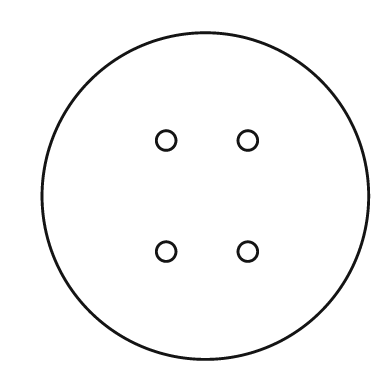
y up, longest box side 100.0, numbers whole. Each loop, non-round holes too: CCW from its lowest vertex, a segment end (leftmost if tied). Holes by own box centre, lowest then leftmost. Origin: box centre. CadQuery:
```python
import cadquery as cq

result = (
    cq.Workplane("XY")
    .moveTo(0.0, 0.0)
    .circle(50.0)
    .moveTo(-12.0, -17.0)
    .circle(3.0)
    .moveTo(13.0, -17.0)
    .circle(3.0)
    .moveTo(-12.0, 17.0)
    .circle(3.0)
    .moveTo(13.0, 17.0)
    .circle(3.0)
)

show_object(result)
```